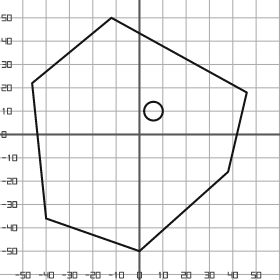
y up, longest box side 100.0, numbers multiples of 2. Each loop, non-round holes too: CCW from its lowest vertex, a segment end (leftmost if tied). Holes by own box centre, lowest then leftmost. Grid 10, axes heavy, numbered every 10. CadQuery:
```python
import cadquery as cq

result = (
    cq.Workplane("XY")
    .moveTo(0.0, -50.0)
    .lineTo(38.0, -16.0)
    .lineTo(46.0, 18.0)
    .lineTo(-12.0, 50.0)
    .lineTo(-46.0, 22.0)
    .lineTo(-40.0, -36.0)
    .close()
    .moveTo(6.0, 10.0)
    .circle(4.0)
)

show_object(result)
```